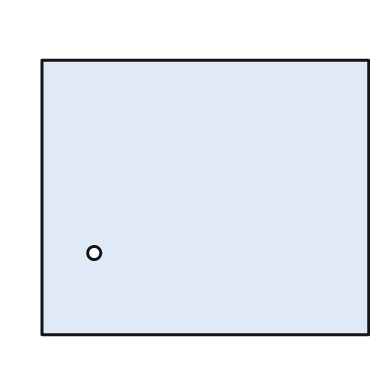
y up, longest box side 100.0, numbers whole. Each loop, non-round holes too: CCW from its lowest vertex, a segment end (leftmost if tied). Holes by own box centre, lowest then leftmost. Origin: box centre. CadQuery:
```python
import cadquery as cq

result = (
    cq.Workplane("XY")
    .moveTo(-50.0, -42.0)
    .lineTo(50.0, -42.0)
    .lineTo(50.0, 42.0)
    .lineTo(-50.0, 42.0)
    .close()
    .moveTo(-34.0, -17.0)
    .circle(2.0)
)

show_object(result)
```